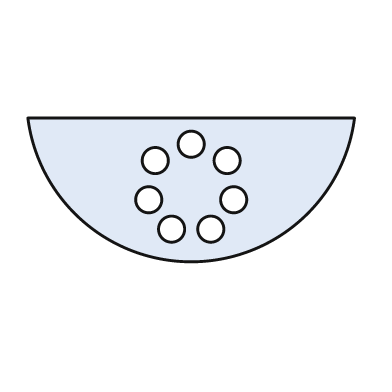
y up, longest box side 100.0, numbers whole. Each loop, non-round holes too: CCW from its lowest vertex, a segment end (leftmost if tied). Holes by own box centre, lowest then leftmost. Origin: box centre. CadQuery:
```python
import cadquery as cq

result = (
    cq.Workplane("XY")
    .moveTo(-50.0, 22.0)
    .threePointArc((0.0, -22.0), (50.0, 22.0))
    .close()
    .moveTo(-6.0, -12.0)
    .circle(4.0)
    .moveTo(6.0, -12.0)
    .circle(4.0)
    .moveTo(-13.0, -3.0)
    .circle(4.0)
    .moveTo(13.0, -3.0)
    .circle(4.0)
    .moveTo(-11.0, 9.0)
    .circle(4.0)
    .moveTo(11.0, 9.0)
    .circle(4.0)
    .moveTo(0.0, 14.0)
    .circle(4.0)
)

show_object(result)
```